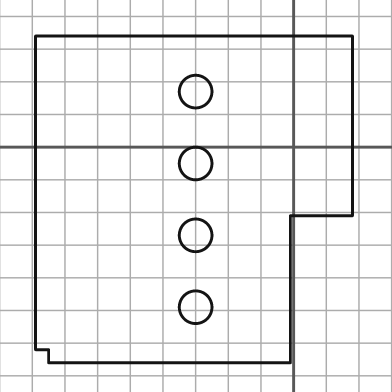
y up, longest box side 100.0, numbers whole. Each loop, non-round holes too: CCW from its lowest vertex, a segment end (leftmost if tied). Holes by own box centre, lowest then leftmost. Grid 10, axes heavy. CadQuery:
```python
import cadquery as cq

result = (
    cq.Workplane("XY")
    .moveTo(-75.0, -66.0)
    .lineTo(-1.0, -66.0)
    .lineTo(-1.0, -21.0)
    .lineTo(18.0, -21.0)
    .lineTo(18.0, 34.0)
    .lineTo(-79.0, 34.0)
    .lineTo(-79.0, -62.0)
    .lineTo(-75.0, -62.0)
    .close()
    .moveTo(-30.0, -49.0)
    .circle(5.0)
    .moveTo(-30.0, -27.0)
    .circle(5.0)
    .moveTo(-30.0, -5.0)
    .circle(5.0)
    .moveTo(-30.0, 17.0)
    .circle(5.0)
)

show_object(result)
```